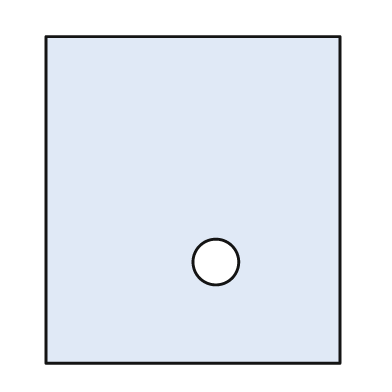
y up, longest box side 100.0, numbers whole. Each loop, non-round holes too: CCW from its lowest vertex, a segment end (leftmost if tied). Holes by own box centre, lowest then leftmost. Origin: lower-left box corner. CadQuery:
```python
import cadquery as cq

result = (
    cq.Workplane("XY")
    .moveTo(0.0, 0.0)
    .lineTo(90.0, 0.0)
    .lineTo(90.0, 100.0)
    .lineTo(0.0, 100.0)
    .close()
    .moveTo(52.0, 31.0)
    .circle(7.0)
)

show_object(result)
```